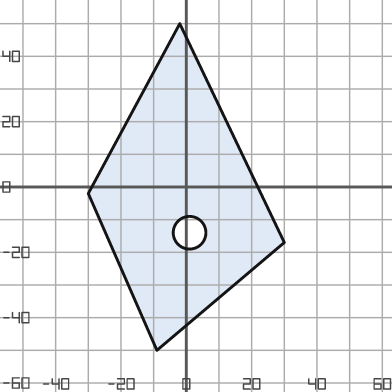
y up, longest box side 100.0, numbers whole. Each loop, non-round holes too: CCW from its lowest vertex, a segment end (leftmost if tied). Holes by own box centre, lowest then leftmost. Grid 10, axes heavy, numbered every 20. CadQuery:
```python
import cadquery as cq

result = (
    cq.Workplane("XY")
    .moveTo(-9.0, -50.0)
    .lineTo(30.0, -17.0)
    .lineTo(-2.0, 50.0)
    .lineTo(-30.0, -2.0)
    .close()
    .moveTo(1.0, -14.0)
    .circle(5.0)
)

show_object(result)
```